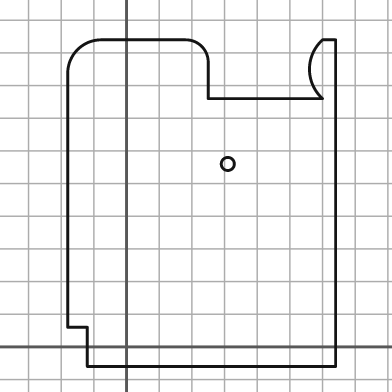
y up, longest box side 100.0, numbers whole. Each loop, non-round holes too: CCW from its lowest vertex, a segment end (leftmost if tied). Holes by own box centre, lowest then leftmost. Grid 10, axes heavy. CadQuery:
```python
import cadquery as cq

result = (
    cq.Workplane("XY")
    .moveTo(-12.0, -6.0)
    .lineTo(64.0, -6.0)
    .lineTo(64.0, 94.0)
    .lineTo(60.0, 94.0)
    .threePointArc((56.0, 85.0), (60.0, 76.0))
    .lineTo(25.0, 76.0)
    .lineTo(25.0, 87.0)
    .threePointArc((23.0, 92.0), (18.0, 94.0))
    .lineTo(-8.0, 94.0)
    .threePointArc((-15.0, 91.0), (-18.0, 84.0))
    .lineTo(-18.0, 6.0)
    .lineTo(-12.0, 6.0)
    .close()
    .moveTo(31.0, 56.0)
    .circle(2.0)
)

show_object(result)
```